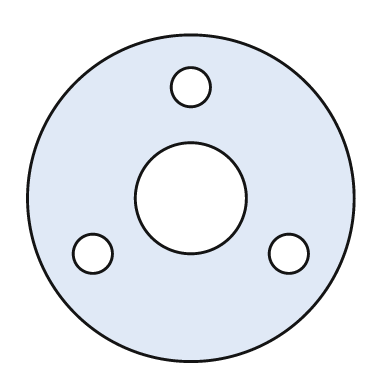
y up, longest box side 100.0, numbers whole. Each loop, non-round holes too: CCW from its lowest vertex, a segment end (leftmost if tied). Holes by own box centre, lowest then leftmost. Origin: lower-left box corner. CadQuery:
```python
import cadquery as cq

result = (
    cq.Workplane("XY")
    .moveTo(50.0, 50.0)
    .circle(50.0)
    .moveTo(20.0, 33.0)
    .circle(6.0)
    .moveTo(80.0, 33.0)
    .circle(6.0)
    .moveTo(50.0, 50.0)
    .circle(17.0)
    .moveTo(50.0, 84.0)
    .circle(6.0)
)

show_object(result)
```